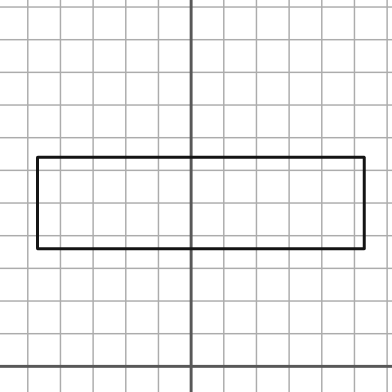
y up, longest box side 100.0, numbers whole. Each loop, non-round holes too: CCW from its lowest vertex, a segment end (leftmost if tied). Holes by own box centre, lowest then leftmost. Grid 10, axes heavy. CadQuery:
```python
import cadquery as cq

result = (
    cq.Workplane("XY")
    .moveTo(-47.0, 36.0)
    .lineTo(53.0, 36.0)
    .lineTo(53.0, 64.0)
    .lineTo(-47.0, 64.0)
    .close()
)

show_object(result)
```